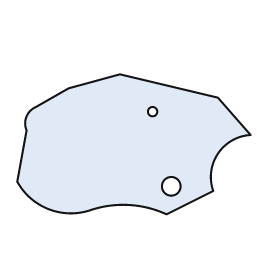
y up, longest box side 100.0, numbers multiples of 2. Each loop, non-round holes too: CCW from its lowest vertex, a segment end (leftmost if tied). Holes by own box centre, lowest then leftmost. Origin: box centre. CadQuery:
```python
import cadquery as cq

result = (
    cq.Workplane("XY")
    .moveTo(14.0, -30.0)
    .lineTo(34.0, -20.0)
    .threePointArc((36.0, -4.0), (50.0, 4.0))
    .lineTo(36.0, 20.0)
    .lineTo(-6.0, 30.0)
    .lineTo(-28.0, 24.0)
    .lineTo(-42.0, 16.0)
    .threePointArc((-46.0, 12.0), (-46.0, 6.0))
    .lineTo(-50.0, -16.0)
    .threePointArc((-36.0, -28.0), (-18.0, -28.0))
    .threePointArc((-2.0, -26.0), (14.0, -30.0))
    .close()
    .moveTo(16.0, -18.0)
    .circle(4.0)
    .moveTo(8.0, 14.0)
    .circle(2.0)
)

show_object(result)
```